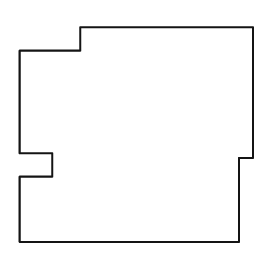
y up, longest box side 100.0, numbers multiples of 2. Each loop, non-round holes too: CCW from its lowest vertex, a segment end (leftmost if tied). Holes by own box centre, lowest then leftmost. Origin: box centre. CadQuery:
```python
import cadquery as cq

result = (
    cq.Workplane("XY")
    .moveTo(-50.0, -46.0)
    .lineTo(44.0, -46.0)
    .lineTo(44.0, -10.0)
    .lineTo(50.0, -10.0)
    .lineTo(50.0, 46.0)
    .lineTo(-24.0, 46.0)
    .lineTo(-24.0, 36.0)
    .lineTo(-50.0, 36.0)
    .lineTo(-50.0, -8.0)
    .lineTo(-36.0, -8.0)
    .lineTo(-36.0, -18.0)
    .lineTo(-50.0, -18.0)
    .close()
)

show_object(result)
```